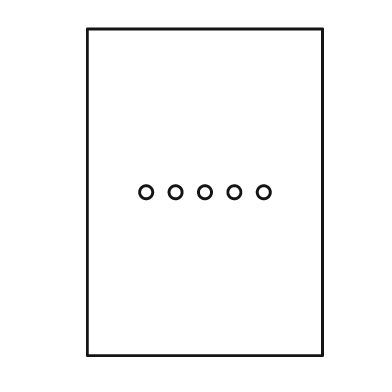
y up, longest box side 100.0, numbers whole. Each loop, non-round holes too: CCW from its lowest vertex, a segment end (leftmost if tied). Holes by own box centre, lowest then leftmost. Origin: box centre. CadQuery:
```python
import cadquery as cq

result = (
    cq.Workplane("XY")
    .moveTo(-36.0, -50.0)
    .lineTo(36.0, -50.0)
    .lineTo(36.0, 50.0)
    .lineTo(-36.0, 50.0)
    .close()
    .moveTo(-18.0, 0.0)
    .circle(2.0)
    .moveTo(-9.0, 0.0)
    .circle(2.0)
    .moveTo(0.0, 0.0)
    .circle(2.0)
    .moveTo(9.0, 0.0)
    .circle(2.0)
    .moveTo(18.0, 0.0)
    .circle(2.0)
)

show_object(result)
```